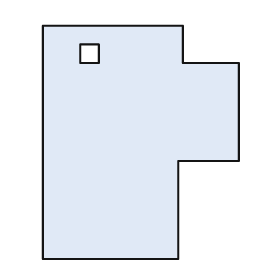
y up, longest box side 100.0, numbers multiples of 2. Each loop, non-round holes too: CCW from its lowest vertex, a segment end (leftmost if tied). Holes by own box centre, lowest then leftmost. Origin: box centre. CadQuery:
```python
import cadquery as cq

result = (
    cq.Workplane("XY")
    .moveTo(-42.0, -50.0)
    .lineTo(16.0, -50.0)
    .lineTo(16.0, -8.0)
    .lineTo(42.0, -8.0)
    .lineTo(42.0, 34.0)
    .lineTo(18.0, 34.0)
    .lineTo(18.0, 50.0)
    .lineTo(-42.0, 50.0)
    .close()
    .moveTo(-26.0, 34.0)
    .lineTo(-18.0, 34.0)
    .lineTo(-18.0, 42.0)
    .lineTo(-26.0, 42.0)
    .close()
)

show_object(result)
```